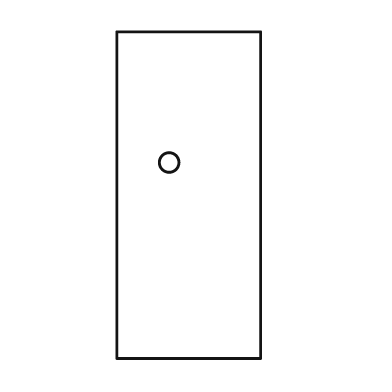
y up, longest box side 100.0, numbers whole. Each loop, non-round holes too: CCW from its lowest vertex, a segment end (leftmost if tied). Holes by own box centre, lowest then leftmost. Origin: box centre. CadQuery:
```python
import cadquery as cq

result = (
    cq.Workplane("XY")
    .moveTo(-22.0, -50.0)
    .lineTo(22.0, -50.0)
    .lineTo(22.0, 50.0)
    .lineTo(-22.0, 50.0)
    .close()
    .moveTo(-6.0, 10.0)
    .circle(3.0)
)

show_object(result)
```